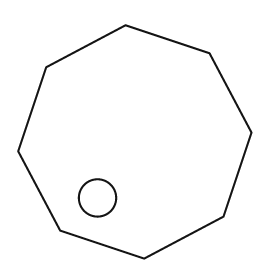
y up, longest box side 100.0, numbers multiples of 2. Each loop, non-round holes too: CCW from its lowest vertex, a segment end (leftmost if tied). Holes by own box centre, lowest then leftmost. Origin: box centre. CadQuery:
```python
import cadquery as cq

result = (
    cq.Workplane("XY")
    .moveTo(4.0, -50.0)
    .lineTo(38.0, -32.0)
    .lineTo(50.0, 4.0)
    .lineTo(32.0, 38.0)
    .lineTo(-4.0, 50.0)
    .lineTo(-38.0, 32.0)
    .lineTo(-50.0, -4.0)
    .lineTo(-32.0, -38.0)
    .close()
    .moveTo(-16.0, -24.0)
    .circle(8.0)
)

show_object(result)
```